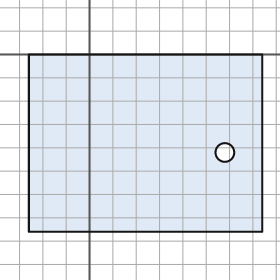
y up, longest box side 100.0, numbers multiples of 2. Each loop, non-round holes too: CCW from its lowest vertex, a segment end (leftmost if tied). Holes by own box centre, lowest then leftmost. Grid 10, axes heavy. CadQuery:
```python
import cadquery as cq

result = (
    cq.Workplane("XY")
    .moveTo(-26.0, -76.0)
    .lineTo(74.0, -76.0)
    .lineTo(74.0, 0.0)
    .lineTo(-26.0, 0.0)
    .close()
    .moveTo(58.0, -42.0)
    .circle(4.0)
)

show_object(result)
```